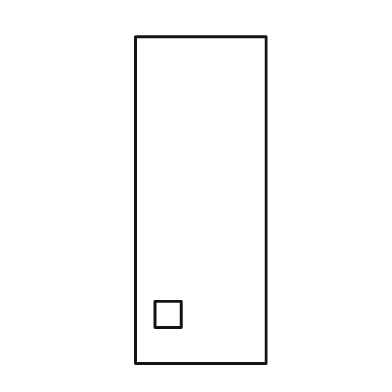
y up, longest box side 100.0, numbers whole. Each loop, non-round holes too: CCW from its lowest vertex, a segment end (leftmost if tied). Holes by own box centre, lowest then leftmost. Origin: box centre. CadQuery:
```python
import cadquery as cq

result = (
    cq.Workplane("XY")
    .moveTo(-20.0, -50.0)
    .lineTo(20.0, -50.0)
    .lineTo(20.0, 50.0)
    .lineTo(-20.0, 50.0)
    .close()
    .moveTo(-14.0, -39.0)
    .lineTo(-6.0, -39.0)
    .lineTo(-6.0, -31.0)
    .lineTo(-14.0, -31.0)
    .close()
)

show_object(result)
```